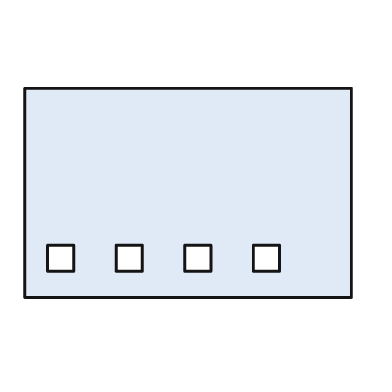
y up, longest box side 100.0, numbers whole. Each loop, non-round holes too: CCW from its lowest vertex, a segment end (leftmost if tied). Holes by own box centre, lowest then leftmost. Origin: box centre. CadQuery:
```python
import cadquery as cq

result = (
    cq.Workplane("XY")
    .moveTo(-50.0, -32.0)
    .lineTo(50.0, -32.0)
    .lineTo(50.0, 32.0)
    .lineTo(-50.0, 32.0)
    .close()
    .moveTo(-43.0, -24.0)
    .lineTo(-35.0, -24.0)
    .lineTo(-35.0, -16.0)
    .lineTo(-43.0, -16.0)
    .close()
    .moveTo(-22.0, -24.0)
    .lineTo(-14.0, -24.0)
    .lineTo(-14.0, -16.0)
    .lineTo(-22.0, -16.0)
    .close()
    .moveTo(-1.0, -24.0)
    .lineTo(7.0, -24.0)
    .lineTo(7.0, -16.0)
    .lineTo(-1.0, -16.0)
    .close()
    .moveTo(20.0, -24.0)
    .lineTo(28.0, -24.0)
    .lineTo(28.0, -16.0)
    .lineTo(20.0, -16.0)
    .close()
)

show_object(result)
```